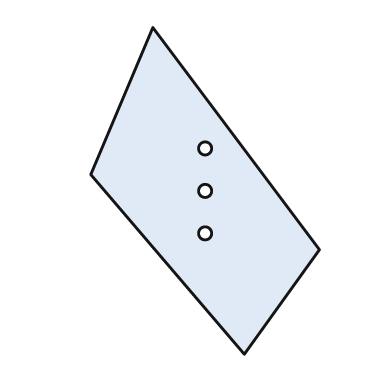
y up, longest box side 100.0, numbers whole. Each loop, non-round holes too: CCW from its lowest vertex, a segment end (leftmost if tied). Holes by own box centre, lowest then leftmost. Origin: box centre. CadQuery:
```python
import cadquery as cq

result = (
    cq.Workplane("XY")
    .moveTo(12.0, -50.0)
    .lineTo(35.0, -18.0)
    .lineTo(-16.0, 50.0)
    .lineTo(-35.0, 5.0)
    .close()
    .moveTo(0.0, -13.0)
    .circle(2.0)
    .moveTo(0.0, 0.0)
    .circle(2.0)
    .moveTo(0.0, 13.0)
    .circle(2.0)
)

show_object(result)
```